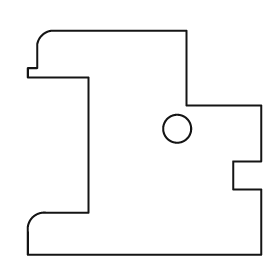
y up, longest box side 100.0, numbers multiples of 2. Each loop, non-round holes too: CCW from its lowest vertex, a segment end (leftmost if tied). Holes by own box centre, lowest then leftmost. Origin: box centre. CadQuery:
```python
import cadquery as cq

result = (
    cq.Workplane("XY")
    .moveTo(-50.0, -48.0)
    .lineTo(50.0, -48.0)
    .lineTo(50.0, -20.0)
    .lineTo(38.0, -20.0)
    .lineTo(38.0, -8.0)
    .lineTo(50.0, -8.0)
    .lineTo(50.0, 16.0)
    .lineTo(18.0, 16.0)
    .lineTo(18.0, 48.0)
    .lineTo(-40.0, 48.0)
    .threePointArc((-44.0, 46.0), (-46.0, 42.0))
    .lineTo(-46.0, 32.0)
    .lineTo(-50.0, 32.0)
    .lineTo(-50.0, 28.0)
    .lineTo(-24.0, 28.0)
    .lineTo(-24.0, -30.0)
    .lineTo(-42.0, -30.0)
    .threePointArc((-48.0, -32.0), (-50.0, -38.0))
    .close()
    .moveTo(14.0, 6.0)
    .circle(6.0)
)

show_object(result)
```